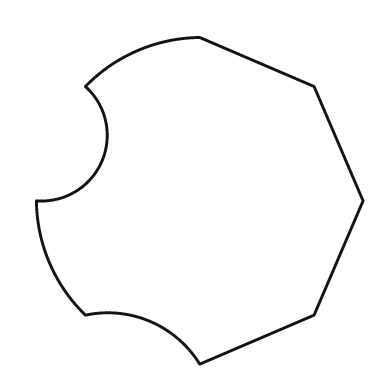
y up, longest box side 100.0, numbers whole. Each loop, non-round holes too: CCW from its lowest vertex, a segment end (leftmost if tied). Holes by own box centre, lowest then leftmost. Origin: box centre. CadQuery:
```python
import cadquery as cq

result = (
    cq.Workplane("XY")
    .moveTo(0.0, -50.0)
    .lineTo(35.0, -35.0)
    .lineTo(50.0, 0.0)
    .lineTo(35.0, 35.0)
    .lineTo(0.0, 50.0)
    .threePointArc((-19.0, 46.0), (-35.0, 35.0))
    .threePointArc((-30.0, 12.0), (-50.0, 0.0))
    .threePointArc((-46.0, -19.0), (-35.0, -35.0))
    .threePointArc((-15.0, -37.0), (0.0, -50.0))
    .close()
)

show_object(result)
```